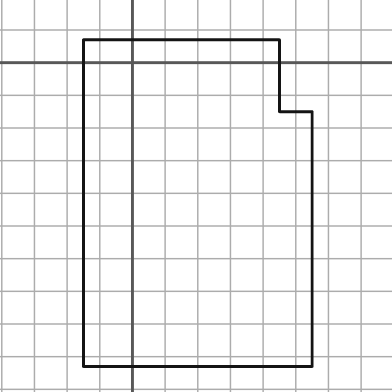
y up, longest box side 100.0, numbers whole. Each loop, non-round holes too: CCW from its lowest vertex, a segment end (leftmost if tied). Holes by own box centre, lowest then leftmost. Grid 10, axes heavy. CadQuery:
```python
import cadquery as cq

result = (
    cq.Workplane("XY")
    .moveTo(-15.0, -93.0)
    .lineTo(55.0, -93.0)
    .lineTo(55.0, -15.0)
    .lineTo(45.0, -15.0)
    .lineTo(45.0, 7.0)
    .lineTo(-15.0, 7.0)
    .close()
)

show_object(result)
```